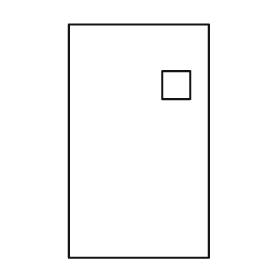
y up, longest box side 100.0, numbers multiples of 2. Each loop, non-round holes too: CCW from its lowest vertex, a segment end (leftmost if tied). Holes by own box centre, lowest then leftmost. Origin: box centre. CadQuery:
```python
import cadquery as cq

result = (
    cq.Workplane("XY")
    .moveTo(-30.0, -50.0)
    .lineTo(30.0, -50.0)
    .lineTo(30.0, 50.0)
    .lineTo(-30.0, 50.0)
    .close()
    .moveTo(10.0, 18.0)
    .lineTo(22.0, 18.0)
    .lineTo(22.0, 30.0)
    .lineTo(10.0, 30.0)
    .close()
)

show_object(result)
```